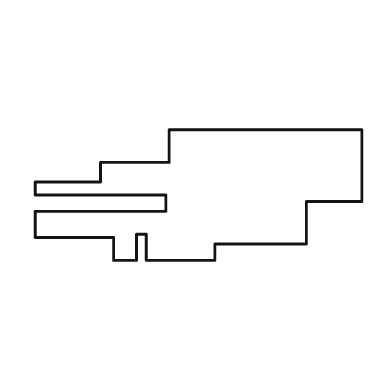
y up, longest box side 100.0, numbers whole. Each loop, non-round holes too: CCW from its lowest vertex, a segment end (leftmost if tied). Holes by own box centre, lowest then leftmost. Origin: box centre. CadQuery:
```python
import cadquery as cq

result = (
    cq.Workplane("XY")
    .moveTo(-26.0, -20.0)
    .lineTo(-19.0, -20.0)
    .lineTo(-19.0, -12.0)
    .lineTo(-16.0, -12.0)
    .lineTo(-16.0, -20.0)
    .lineTo(5.0, -20.0)
    .lineTo(5.0, -15.0)
    .lineTo(33.0, -15.0)
    .lineTo(33.0, -2.0)
    .lineTo(50.0, -2.0)
    .lineTo(50.0, 20.0)
    .lineTo(-9.0, 20.0)
    .lineTo(-9.0, 10.0)
    .lineTo(-30.0, 10.0)
    .lineTo(-30.0, 4.0)
    .lineTo(-50.0, 4.0)
    .lineTo(-50.0, 0.0)
    .lineTo(-10.0, 0.0)
    .lineTo(-10.0, -5.0)
    .lineTo(-50.0, -5.0)
    .lineTo(-50.0, -13.0)
    .lineTo(-26.0, -13.0)
    .close()
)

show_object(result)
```